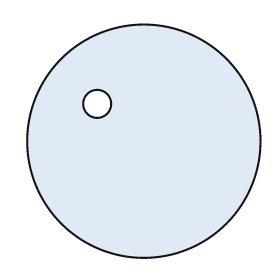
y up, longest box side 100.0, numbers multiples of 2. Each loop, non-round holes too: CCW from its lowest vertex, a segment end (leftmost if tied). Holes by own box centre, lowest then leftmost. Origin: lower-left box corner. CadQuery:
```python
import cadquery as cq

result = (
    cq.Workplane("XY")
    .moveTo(50.0, 50.0)
    .circle(50.0)
    .moveTo(30.0, 66.0)
    .circle(6.0)
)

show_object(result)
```